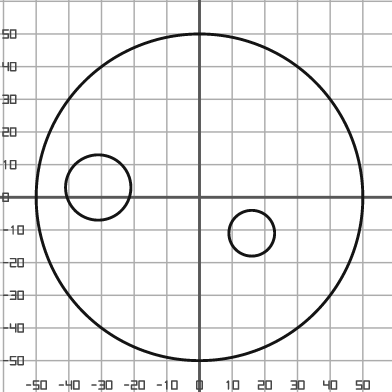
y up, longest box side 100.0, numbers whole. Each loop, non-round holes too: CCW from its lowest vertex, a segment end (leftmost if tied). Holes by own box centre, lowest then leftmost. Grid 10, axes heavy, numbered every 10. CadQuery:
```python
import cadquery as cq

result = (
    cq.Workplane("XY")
    .moveTo(0.0, 0.0)
    .circle(50.0)
    .moveTo(16.0, -11.0)
    .circle(7.0)
    .moveTo(-31.0, 3.0)
    .circle(10.0)
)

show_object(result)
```